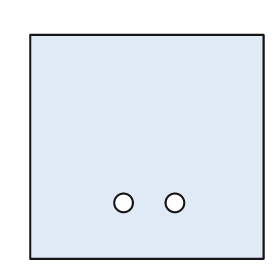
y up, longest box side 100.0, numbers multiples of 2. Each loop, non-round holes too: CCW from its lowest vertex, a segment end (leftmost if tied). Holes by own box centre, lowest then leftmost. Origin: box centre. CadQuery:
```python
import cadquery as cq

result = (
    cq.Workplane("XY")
    .moveTo(-50.0, -48.0)
    .lineTo(50.0, -48.0)
    .lineTo(50.0, 48.0)
    .lineTo(-50.0, 48.0)
    .close()
    .moveTo(-10.0, -24.0)
    .circle(4.0)
    .moveTo(12.0, -24.0)
    .circle(4.0)
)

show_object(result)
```